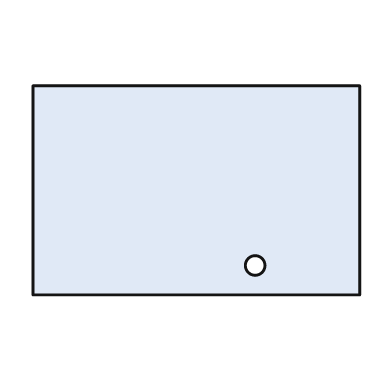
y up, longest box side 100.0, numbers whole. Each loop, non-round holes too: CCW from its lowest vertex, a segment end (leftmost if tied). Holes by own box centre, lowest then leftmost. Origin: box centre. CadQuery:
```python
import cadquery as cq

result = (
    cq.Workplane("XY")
    .moveTo(-50.0, -32.0)
    .lineTo(50.0, -32.0)
    .lineTo(50.0, 32.0)
    .lineTo(-50.0, 32.0)
    .close()
    .moveTo(18.0, -23.0)
    .circle(3.0)
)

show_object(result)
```